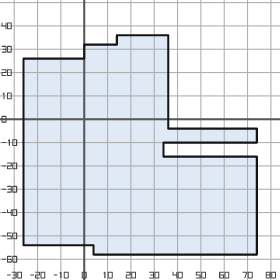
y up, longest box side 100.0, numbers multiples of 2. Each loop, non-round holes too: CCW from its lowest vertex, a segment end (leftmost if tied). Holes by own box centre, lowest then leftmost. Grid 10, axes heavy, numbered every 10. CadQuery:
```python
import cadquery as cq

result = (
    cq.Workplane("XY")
    .moveTo(4.0, -58.0)
    .lineTo(74.0, -58.0)
    .lineTo(74.0, -16.0)
    .lineTo(34.0, -16.0)
    .lineTo(34.0, -10.0)
    .lineTo(74.0, -10.0)
    .lineTo(74.0, -4.0)
    .lineTo(36.0, -4.0)
    .lineTo(36.0, 36.0)
    .lineTo(14.0, 36.0)
    .lineTo(14.0, 32.0)
    .lineTo(0.0, 32.0)
    .lineTo(0.0, 26.0)
    .lineTo(-26.0, 26.0)
    .lineTo(-26.0, -54.0)
    .lineTo(4.0, -54.0)
    .close()
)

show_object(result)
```